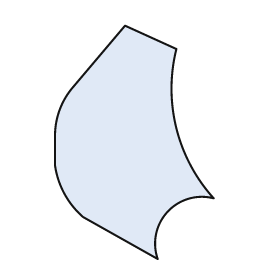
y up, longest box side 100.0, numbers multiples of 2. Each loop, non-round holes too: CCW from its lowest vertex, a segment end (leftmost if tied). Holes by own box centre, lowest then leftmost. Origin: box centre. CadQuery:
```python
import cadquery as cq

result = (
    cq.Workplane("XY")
    .moveTo(10.0, -50.0)
    .threePointArc((14.0, -30.0), (34.0, -24.0))
    .threePointArc((18.0, 6.0), (18.0, 40.0))
    .lineTo(-4.0, 50.0)
    .lineTo(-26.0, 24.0)
    .threePointArc((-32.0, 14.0), (-34.0, 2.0))
    .lineTo(-34.0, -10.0)
    .threePointArc((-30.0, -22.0), (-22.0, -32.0))
    .close()
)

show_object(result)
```